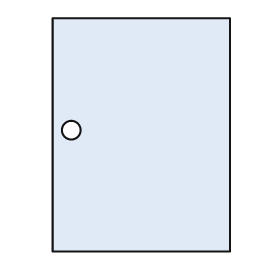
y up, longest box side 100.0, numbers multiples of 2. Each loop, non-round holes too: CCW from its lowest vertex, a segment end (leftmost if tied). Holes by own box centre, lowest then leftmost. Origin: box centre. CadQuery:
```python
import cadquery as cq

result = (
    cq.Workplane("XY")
    .moveTo(-38.0, -50.0)
    .lineTo(38.0, -50.0)
    .lineTo(38.0, 50.0)
    .lineTo(-38.0, 50.0)
    .close()
    .moveTo(-30.0, 2.0)
    .circle(4.0)
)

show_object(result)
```